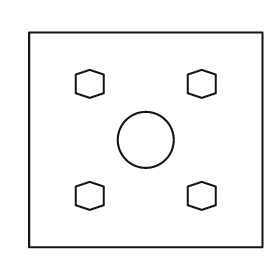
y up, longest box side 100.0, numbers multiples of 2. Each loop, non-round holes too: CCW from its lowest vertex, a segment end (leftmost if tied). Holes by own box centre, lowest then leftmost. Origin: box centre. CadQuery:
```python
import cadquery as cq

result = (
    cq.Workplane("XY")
    .moveTo(-50.0, -46.0)
    .lineTo(50.0, -46.0)
    .lineTo(50.0, 46.0)
    .lineTo(-50.0, 46.0)
    .close()
    .moveTo(-24.0, -30.0)
    .lineTo(-18.0, -28.0)
    .lineTo(-18.0, -20.0)
    .lineTo(-24.0, -18.0)
    .lineTo(-30.0, -20.0)
    .lineTo(-30.0, -28.0)
    .close()
    .moveTo(24.0, -30.0)
    .lineTo(30.0, -28.0)
    .lineTo(30.0, -20.0)
    .lineTo(24.0, -18.0)
    .lineTo(18.0, -20.0)
    .lineTo(18.0, -28.0)
    .close()
    .moveTo(0.0, 0.0)
    .circle(12.0)
    .moveTo(-24.0, 18.0)
    .lineTo(-18.0, 20.0)
    .lineTo(-18.0, 28.0)
    .lineTo(-24.0, 30.0)
    .lineTo(-30.0, 28.0)
    .lineTo(-30.0, 20.0)
    .close()
    .moveTo(24.0, 18.0)
    .lineTo(30.0, 20.0)
    .lineTo(30.0, 28.0)
    .lineTo(24.0, 30.0)
    .lineTo(18.0, 28.0)
    .lineTo(18.0, 20.0)
    .close()
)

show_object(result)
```